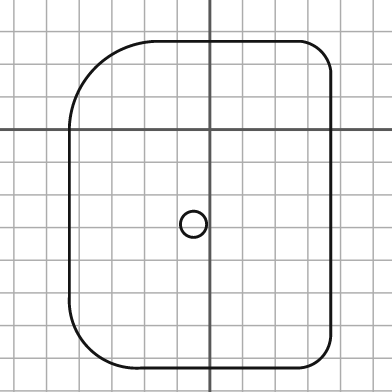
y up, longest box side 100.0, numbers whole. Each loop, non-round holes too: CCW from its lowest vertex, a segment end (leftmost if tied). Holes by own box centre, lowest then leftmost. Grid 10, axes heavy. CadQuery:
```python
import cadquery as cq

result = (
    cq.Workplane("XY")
    .moveTo(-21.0, -73.0)
    .lineTo(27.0, -73.0)
    .threePointArc((34.0, -70.0), (37.0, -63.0))
    .lineTo(37.0, 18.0)
    .threePointArc((34.0, 24.0), (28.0, 27.0))
    .lineTo(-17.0, 27.0)
    .threePointArc((-35.0, 19.0), (-43.0, 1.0))
    .lineTo(-43.0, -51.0)
    .threePointArc((-37.0, -67.0), (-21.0, -73.0))
    .close()
    .moveTo(-5.0, -29.0)
    .circle(4.0)
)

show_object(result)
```